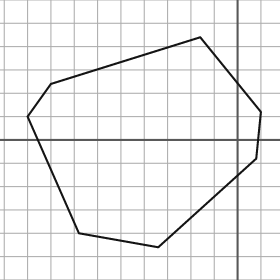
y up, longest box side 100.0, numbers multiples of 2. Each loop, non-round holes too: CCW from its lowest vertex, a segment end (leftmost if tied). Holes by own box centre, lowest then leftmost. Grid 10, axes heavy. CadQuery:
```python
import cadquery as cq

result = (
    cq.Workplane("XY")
    .moveTo(-34.0, -46.0)
    .lineTo(8.0, -8.0)
    .lineTo(10.0, 12.0)
    .lineTo(-16.0, 44.0)
    .lineTo(-80.0, 24.0)
    .lineTo(-90.0, 10.0)
    .lineTo(-68.0, -40.0)
    .close()
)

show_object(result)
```